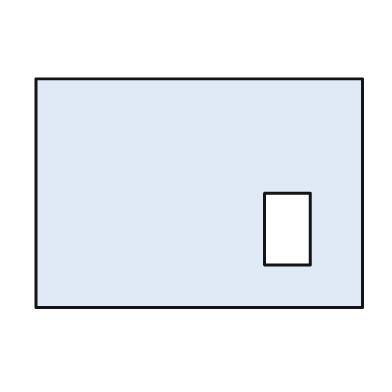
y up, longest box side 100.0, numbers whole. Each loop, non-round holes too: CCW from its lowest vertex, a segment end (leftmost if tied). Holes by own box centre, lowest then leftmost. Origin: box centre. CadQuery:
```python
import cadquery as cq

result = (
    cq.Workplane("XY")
    .moveTo(-50.0, -35.0)
    .lineTo(50.0, -35.0)
    .lineTo(50.0, 35.0)
    .lineTo(-50.0, 35.0)
    .close()
    .moveTo(20.0, -22.0)
    .lineTo(34.0, -22.0)
    .lineTo(34.0, 0.0)
    .lineTo(20.0, 0.0)
    .close()
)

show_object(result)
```